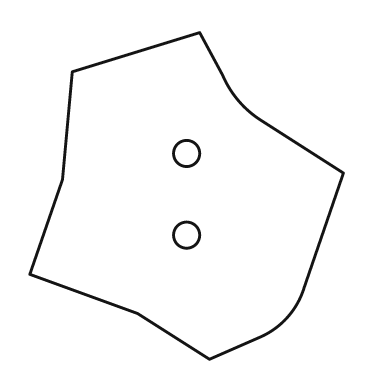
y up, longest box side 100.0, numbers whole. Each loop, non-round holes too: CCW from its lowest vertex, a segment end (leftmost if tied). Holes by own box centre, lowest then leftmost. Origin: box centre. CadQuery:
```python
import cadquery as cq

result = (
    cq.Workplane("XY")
    .moveTo(7.0, -50.0)
    .lineTo(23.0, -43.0)
    .threePointArc((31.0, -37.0), (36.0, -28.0))
    .lineTo(48.0, 7.0)
    .lineTo(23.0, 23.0)
    .threePointArc((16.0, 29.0), (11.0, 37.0))
    .lineTo(4.0, 50.0)
    .lineTo(-35.0, 38.0)
    .lineTo(-38.0, 5.0)
    .lineTo(-48.0, -24.0)
    .lineTo(-15.0, -36.0)
    .close()
    .moveTo(0.0, -12.0)
    .circle(4.0)
    .moveTo(0.0, 13.0)
    .circle(4.0)
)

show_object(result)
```